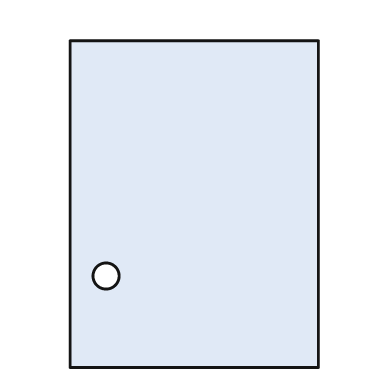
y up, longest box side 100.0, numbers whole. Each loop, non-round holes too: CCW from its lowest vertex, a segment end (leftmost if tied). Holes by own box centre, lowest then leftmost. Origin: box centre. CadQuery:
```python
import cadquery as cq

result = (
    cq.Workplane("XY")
    .moveTo(-38.0, -50.0)
    .lineTo(38.0, -50.0)
    .lineTo(38.0, 50.0)
    .lineTo(-38.0, 50.0)
    .close()
    .moveTo(-27.0, -22.0)
    .circle(4.0)
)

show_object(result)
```